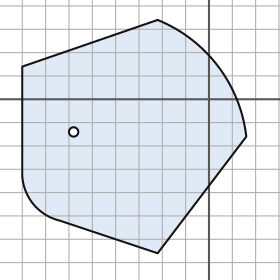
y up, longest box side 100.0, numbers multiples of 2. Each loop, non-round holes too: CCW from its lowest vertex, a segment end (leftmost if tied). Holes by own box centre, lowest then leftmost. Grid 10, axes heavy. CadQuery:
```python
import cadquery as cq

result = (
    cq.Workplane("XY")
    .moveTo(-22.0, -66.0)
    .lineTo(16.0, -16.0)
    .threePointArc((4.0, 14.0), (-22.0, 34.0))
    .lineTo(-80.0, 14.0)
    .lineTo(-80.0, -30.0)
    .threePointArc((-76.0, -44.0), (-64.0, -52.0))
    .close()
    .moveTo(-58.0, -14.0)
    .circle(2.0)
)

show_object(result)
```